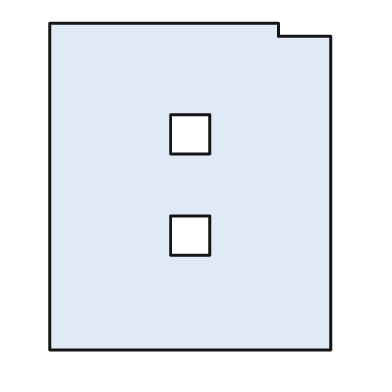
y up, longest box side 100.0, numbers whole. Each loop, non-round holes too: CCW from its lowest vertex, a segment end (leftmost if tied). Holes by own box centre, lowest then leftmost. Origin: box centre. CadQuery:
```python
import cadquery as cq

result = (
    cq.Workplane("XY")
    .moveTo(-43.0, -50.0)
    .lineTo(43.0, -50.0)
    .lineTo(43.0, 46.0)
    .lineTo(27.0, 46.0)
    .lineTo(27.0, 50.0)
    .lineTo(-43.0, 50.0)
    .close()
    .moveTo(-6.0, -21.0)
    .lineTo(6.0, -21.0)
    .lineTo(6.0, -9.0)
    .lineTo(-6.0, -9.0)
    .close()
    .moveTo(-6.0, 10.0)
    .lineTo(6.0, 10.0)
    .lineTo(6.0, 22.0)
    .lineTo(-6.0, 22.0)
    .close()
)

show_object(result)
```